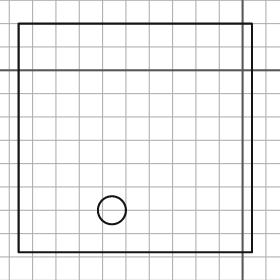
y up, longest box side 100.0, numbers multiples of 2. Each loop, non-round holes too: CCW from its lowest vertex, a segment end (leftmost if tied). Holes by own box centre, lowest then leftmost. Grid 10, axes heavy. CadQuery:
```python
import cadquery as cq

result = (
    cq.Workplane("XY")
    .moveTo(-96.0, -78.0)
    .lineTo(4.0, -78.0)
    .lineTo(4.0, 20.0)
    .lineTo(-96.0, 20.0)
    .close()
    .moveTo(-56.0, -60.0)
    .circle(6.0)
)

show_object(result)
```